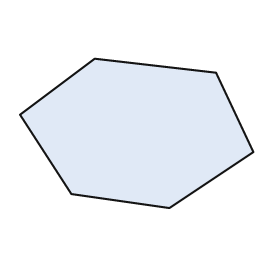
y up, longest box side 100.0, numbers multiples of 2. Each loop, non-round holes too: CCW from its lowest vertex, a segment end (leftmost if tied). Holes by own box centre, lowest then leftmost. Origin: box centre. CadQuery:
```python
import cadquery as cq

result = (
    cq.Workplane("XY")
    .moveTo(14.0, -32.0)
    .lineTo(50.0, -8.0)
    .lineTo(34.0, 26.0)
    .lineTo(-18.0, 32.0)
    .lineTo(-50.0, 8.0)
    .lineTo(-28.0, -26.0)
    .close()
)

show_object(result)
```